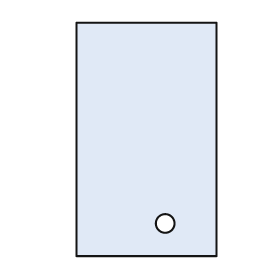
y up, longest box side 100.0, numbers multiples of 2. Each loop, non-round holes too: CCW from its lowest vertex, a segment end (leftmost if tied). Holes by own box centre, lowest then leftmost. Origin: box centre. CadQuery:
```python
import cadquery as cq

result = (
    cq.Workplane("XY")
    .moveTo(-30.0, -50.0)
    .lineTo(30.0, -50.0)
    .lineTo(30.0, 50.0)
    .lineTo(-30.0, 50.0)
    .close()
    .moveTo(8.0, -36.0)
    .circle(4.0)
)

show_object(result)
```